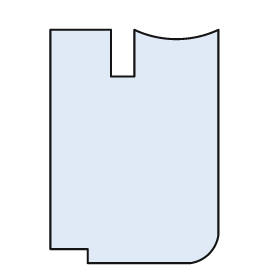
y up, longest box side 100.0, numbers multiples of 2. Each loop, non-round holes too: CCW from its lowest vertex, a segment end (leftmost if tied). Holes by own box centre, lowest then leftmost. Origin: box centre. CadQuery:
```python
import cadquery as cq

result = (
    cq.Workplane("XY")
    .moveTo(-20.0, -50.0)
    .lineTo(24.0, -50.0)
    .threePointArc((32.0, -46.0), (36.0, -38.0))
    .lineTo(36.0, 50.0)
    .threePointArc((18.0, 46.0), (0.0, 50.0))
    .lineTo(0.0, 30.0)
    .lineTo(-10.0, 30.0)
    .lineTo(-10.0, 50.0)
    .lineTo(-36.0, 50.0)
    .lineTo(-36.0, -44.0)
    .lineTo(-20.0, -44.0)
    .close()
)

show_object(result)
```